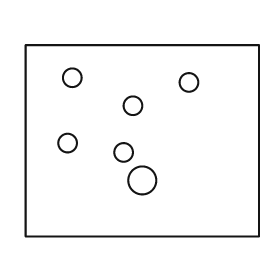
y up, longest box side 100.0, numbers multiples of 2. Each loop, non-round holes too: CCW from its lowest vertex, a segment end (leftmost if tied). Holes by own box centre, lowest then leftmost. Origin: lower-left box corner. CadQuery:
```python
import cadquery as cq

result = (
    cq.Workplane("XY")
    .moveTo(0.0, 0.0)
    .lineTo(100.0, 0.0)
    .lineTo(100.0, 82.0)
    .lineTo(0.0, 82.0)
    .close()
    .moveTo(50.0, 24.0)
    .circle(6.0)
    .moveTo(42.0, 36.0)
    .circle(4.0)
    .moveTo(18.0, 40.0)
    .circle(4.0)
    .moveTo(46.0, 56.0)
    .circle(4.0)
    .moveTo(70.0, 66.0)
    .circle(4.0)
    .moveTo(20.0, 68.0)
    .circle(4.0)
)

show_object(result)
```